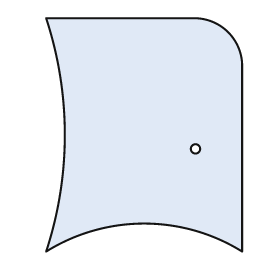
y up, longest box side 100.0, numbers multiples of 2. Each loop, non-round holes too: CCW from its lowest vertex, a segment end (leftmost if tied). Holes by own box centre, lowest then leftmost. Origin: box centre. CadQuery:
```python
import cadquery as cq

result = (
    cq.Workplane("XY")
    .moveTo(-42.0, -50.0)
    .threePointArc((0.0, -38.0), (42.0, -50.0))
    .lineTo(42.0, 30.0)
    .threePointArc((36.0, 44.0), (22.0, 50.0))
    .lineTo(-42.0, 50.0)
    .threePointArc((-34.0, 0.0), (-42.0, -50.0))
    .close()
    .moveTo(22.0, -6.0)
    .circle(2.0)
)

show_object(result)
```